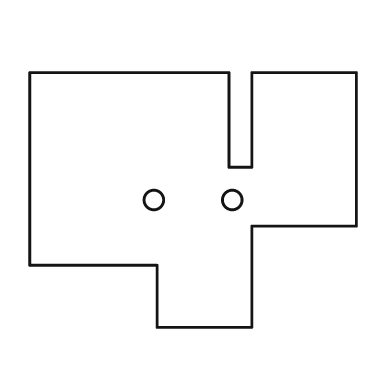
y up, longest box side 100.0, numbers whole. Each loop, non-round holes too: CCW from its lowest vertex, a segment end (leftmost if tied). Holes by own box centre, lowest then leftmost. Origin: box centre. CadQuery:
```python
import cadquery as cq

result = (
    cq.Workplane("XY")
    .moveTo(-11.0, -39.0)
    .lineTo(18.0, -39.0)
    .lineTo(18.0, -8.0)
    .lineTo(50.0, -8.0)
    .lineTo(50.0, 39.0)
    .lineTo(18.0, 39.0)
    .lineTo(18.0, 10.0)
    .lineTo(11.0, 10.0)
    .lineTo(11.0, 39.0)
    .lineTo(-50.0, 39.0)
    .lineTo(-50.0, -20.0)
    .lineTo(-11.0, -20.0)
    .close()
    .moveTo(-12.0, 0.0)
    .circle(3.0)
    .moveTo(12.0, 0.0)
    .circle(3.0)
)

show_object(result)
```